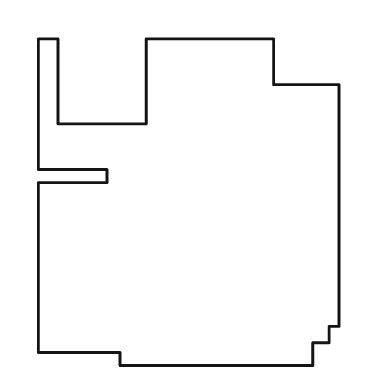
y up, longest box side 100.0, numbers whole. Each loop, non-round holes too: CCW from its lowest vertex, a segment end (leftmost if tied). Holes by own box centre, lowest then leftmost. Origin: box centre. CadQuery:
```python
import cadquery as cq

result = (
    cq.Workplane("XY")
    .moveTo(-21.0, -50.0)
    .lineTo(38.0, -50.0)
    .lineTo(38.0, -43.0)
    .lineTo(43.0, -43.0)
    .lineTo(43.0, -38.0)
    .lineTo(46.0, -38.0)
    .lineTo(46.0, 36.0)
    .lineTo(26.0, 36.0)
    .lineTo(26.0, 50.0)
    .lineTo(-13.0, 50.0)
    .lineTo(-13.0, 24.0)
    .lineTo(-40.0, 24.0)
    .lineTo(-40.0, 50.0)
    .lineTo(-46.0, 50.0)
    .lineTo(-46.0, 10.0)
    .lineTo(-25.0, 10.0)
    .lineTo(-25.0, 6.0)
    .lineTo(-46.0, 6.0)
    .lineTo(-46.0, -46.0)
    .lineTo(-21.0, -46.0)
    .close()
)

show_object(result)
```